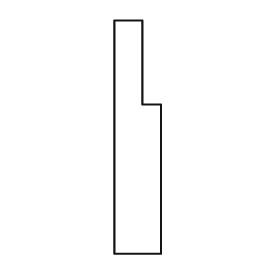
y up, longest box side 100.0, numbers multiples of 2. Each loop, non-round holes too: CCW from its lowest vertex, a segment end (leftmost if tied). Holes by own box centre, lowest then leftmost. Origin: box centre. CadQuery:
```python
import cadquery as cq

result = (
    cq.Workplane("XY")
    .moveTo(-10.0, -50.0)
    .lineTo(10.0, -50.0)
    .lineTo(10.0, 14.0)
    .lineTo(2.0, 14.0)
    .lineTo(2.0, 50.0)
    .lineTo(-10.0, 50.0)
    .close()
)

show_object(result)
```